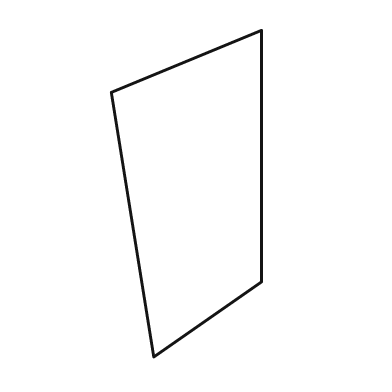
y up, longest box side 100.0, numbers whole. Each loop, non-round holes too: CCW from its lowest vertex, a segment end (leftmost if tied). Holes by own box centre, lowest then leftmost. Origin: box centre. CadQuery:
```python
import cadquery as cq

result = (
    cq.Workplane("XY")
    .moveTo(-10.0, -50.0)
    .lineTo(23.0, -27.0)
    .lineTo(23.0, 50.0)
    .lineTo(-23.0, 31.0)
    .close()
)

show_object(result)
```